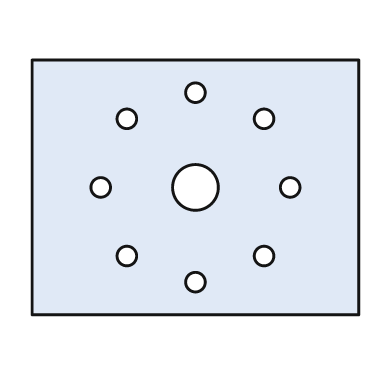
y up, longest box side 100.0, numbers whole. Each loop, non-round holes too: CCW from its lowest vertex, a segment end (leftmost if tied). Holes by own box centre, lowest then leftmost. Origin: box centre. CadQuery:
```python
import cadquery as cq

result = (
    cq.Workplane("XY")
    .moveTo(-50.0, -39.0)
    .lineTo(50.0, -39.0)
    .lineTo(50.0, 39.0)
    .lineTo(-50.0, 39.0)
    .close()
    .moveTo(0.0, -29.0)
    .circle(3.0)
    .moveTo(-21.0, -21.0)
    .circle(3.0)
    .moveTo(21.0, -21.0)
    .circle(3.0)
    .moveTo(-29.0, 0.0)
    .circle(3.0)
    .moveTo(0.0, 0.0)
    .circle(7.0)
    .moveTo(29.0, 0.0)
    .circle(3.0)
    .moveTo(-21.0, 21.0)
    .circle(3.0)
    .moveTo(21.0, 21.0)
    .circle(3.0)
    .moveTo(0.0, 29.0)
    .circle(3.0)
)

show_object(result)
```